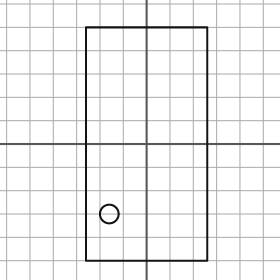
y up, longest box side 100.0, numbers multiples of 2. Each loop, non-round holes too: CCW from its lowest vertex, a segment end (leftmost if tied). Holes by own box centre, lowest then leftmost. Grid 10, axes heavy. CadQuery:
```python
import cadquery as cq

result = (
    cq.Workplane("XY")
    .moveTo(-26.0, -50.0)
    .lineTo(26.0, -50.0)
    .lineTo(26.0, 50.0)
    .lineTo(-26.0, 50.0)
    .close()
    .moveTo(-16.0, -30.0)
    .circle(4.0)
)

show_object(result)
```